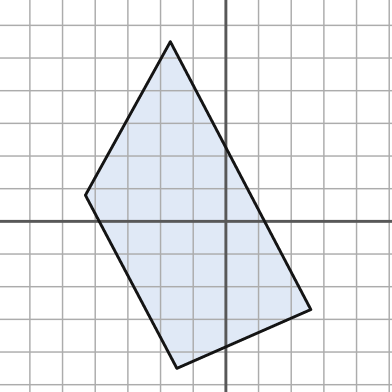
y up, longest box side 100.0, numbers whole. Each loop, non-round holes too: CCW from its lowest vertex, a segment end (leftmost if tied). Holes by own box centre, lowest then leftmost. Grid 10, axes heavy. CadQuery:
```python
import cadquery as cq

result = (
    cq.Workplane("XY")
    .moveTo(-15.0, -45.0)
    .lineTo(26.0, -27.0)
    .lineTo(-17.0, 55.0)
    .lineTo(-43.0, 8.0)
    .close()
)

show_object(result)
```